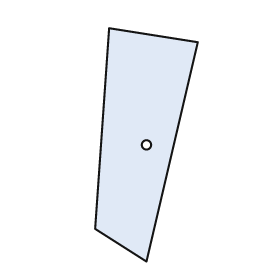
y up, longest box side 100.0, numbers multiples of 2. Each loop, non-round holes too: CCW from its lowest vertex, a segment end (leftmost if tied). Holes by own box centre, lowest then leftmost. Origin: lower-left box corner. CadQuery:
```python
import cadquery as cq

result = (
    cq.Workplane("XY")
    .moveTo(22.0, 0.0)
    .lineTo(44.0, 94.0)
    .lineTo(6.0, 100.0)
    .lineTo(0.0, 14.0)
    .close()
    .moveTo(22.0, 50.0)
    .circle(2.0)
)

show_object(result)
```